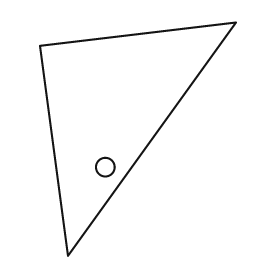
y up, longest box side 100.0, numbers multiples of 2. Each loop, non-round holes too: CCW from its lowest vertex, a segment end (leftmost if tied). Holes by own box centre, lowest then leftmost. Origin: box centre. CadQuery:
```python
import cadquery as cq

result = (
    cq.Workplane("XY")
    .moveTo(-30.0, -50.0)
    .lineTo(42.0, 50.0)
    .lineTo(-42.0, 40.0)
    .close()
    .moveTo(-14.0, -12.0)
    .circle(4.0)
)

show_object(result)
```